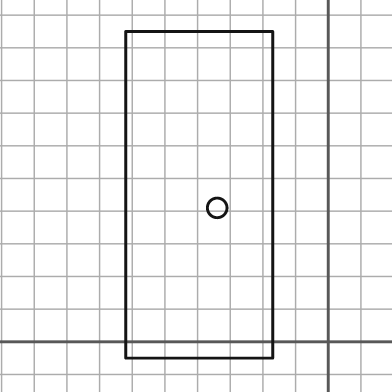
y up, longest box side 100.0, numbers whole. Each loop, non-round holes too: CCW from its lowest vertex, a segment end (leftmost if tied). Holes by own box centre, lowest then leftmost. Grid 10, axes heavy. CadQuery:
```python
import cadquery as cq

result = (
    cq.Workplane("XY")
    .moveTo(-62.0, -5.0)
    .lineTo(-17.0, -5.0)
    .lineTo(-17.0, 95.0)
    .lineTo(-62.0, 95.0)
    .close()
    .moveTo(-34.0, 41.0)
    .circle(3.0)
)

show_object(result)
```